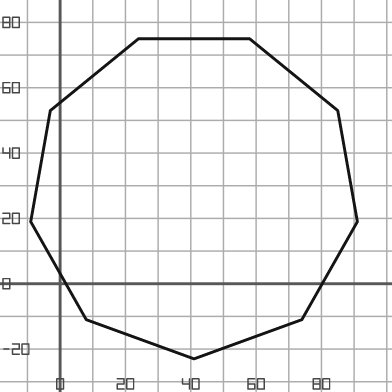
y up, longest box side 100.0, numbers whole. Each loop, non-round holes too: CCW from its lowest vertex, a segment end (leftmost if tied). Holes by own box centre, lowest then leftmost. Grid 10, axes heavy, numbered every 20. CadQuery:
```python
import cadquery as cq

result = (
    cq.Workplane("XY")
    .moveTo(41.0, -23.0)
    .lineTo(74.0, -11.0)
    .lineTo(91.0, 19.0)
    .lineTo(85.0, 53.0)
    .lineTo(58.0, 75.0)
    .lineTo(24.0, 75.0)
    .lineTo(-3.0, 53.0)
    .lineTo(-9.0, 19.0)
    .lineTo(8.0, -11.0)
    .close()
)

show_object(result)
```